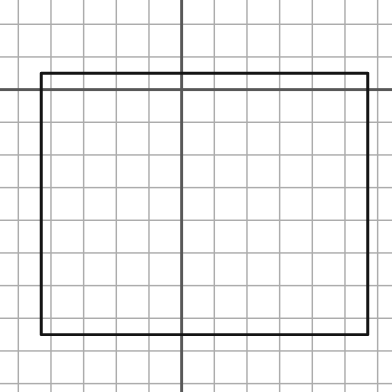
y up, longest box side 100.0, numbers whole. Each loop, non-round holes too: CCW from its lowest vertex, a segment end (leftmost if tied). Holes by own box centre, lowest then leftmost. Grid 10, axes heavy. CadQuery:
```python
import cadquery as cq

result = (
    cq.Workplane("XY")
    .moveTo(-43.0, -75.0)
    .lineTo(57.0, -75.0)
    .lineTo(57.0, 5.0)
    .lineTo(-43.0, 5.0)
    .close()
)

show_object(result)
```